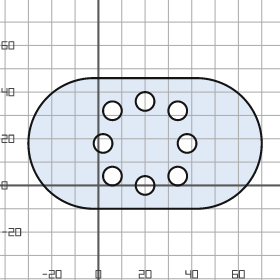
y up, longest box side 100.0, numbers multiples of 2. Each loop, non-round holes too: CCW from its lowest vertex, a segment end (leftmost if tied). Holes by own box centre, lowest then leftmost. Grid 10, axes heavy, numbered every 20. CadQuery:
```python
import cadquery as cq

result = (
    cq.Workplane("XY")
    .moveTo(-2.0, -10.0)
    .lineTo(42.0, -10.0)
    .threePointArc((70.0, 18.0), (42.0, 46.0))
    .lineTo(-2.0, 46.0)
    .threePointArc((-30.0, 18.0), (-2.0, -10.0))
    .close()
    .moveTo(20.0, 0.0)
    .circle(4.0)
    .moveTo(6.0, 4.0)
    .circle(4.0)
    .moveTo(34.0, 4.0)
    .circle(4.0)
    .moveTo(2.0, 18.0)
    .circle(4.0)
    .moveTo(38.0, 18.0)
    .circle(4.0)
    .moveTo(6.0, 32.0)
    .circle(4.0)
    .moveTo(34.0, 32.0)
    .circle(4.0)
    .moveTo(20.0, 36.0)
    .circle(4.0)
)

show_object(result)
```